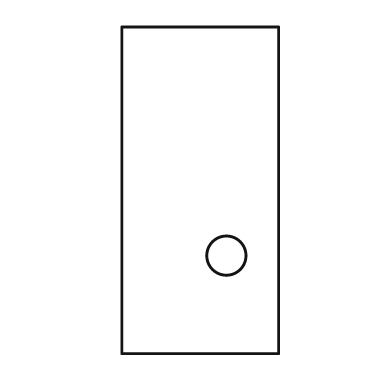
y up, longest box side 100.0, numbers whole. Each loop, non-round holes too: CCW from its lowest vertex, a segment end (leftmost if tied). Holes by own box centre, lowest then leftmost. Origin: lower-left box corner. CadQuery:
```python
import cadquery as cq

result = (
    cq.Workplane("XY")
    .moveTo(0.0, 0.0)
    .lineTo(48.0, 0.0)
    .lineTo(48.0, 100.0)
    .lineTo(0.0, 100.0)
    .close()
    .moveTo(32.0, 30.0)
    .circle(6.0)
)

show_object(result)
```